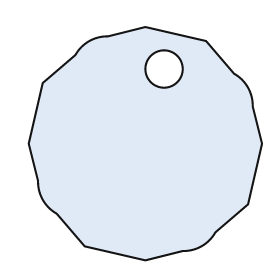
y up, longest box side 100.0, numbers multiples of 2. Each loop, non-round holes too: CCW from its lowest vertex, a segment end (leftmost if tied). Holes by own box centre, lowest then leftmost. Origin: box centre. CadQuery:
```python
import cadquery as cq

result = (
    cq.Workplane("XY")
    .moveTo(0.0, -50.0)
    .lineTo(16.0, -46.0)
    .threePointArc((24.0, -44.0), (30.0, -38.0))
    .lineTo(44.0, -26.0)
    .lineTo(50.0, 0.0)
    .lineTo(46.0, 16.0)
    .threePointArc((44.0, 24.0), (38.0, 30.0))
    .lineTo(26.0, 44.0)
    .lineTo(0.0, 50.0)
    .lineTo(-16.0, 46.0)
    .threePointArc((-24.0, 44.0), (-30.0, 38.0))
    .lineTo(-44.0, 26.0)
    .lineTo(-50.0, 0.0)
    .lineTo(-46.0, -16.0)
    .threePointArc((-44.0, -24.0), (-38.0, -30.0))
    .lineTo(-26.0, -44.0)
    .close()
    .moveTo(8.0, 32.0)
    .circle(8.0)
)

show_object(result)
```